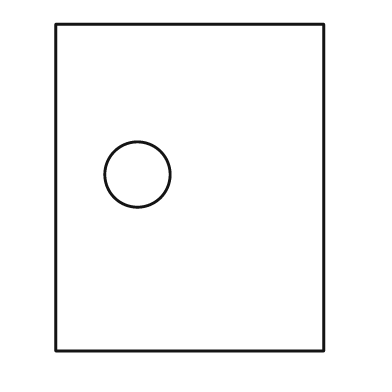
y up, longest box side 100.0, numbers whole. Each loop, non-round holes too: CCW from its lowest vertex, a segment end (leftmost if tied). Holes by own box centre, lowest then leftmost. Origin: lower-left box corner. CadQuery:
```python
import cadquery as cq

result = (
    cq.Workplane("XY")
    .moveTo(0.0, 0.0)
    .lineTo(82.0, 0.0)
    .lineTo(82.0, 100.0)
    .lineTo(0.0, 100.0)
    .close()
    .moveTo(25.0, 54.0)
    .circle(10.0)
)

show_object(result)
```